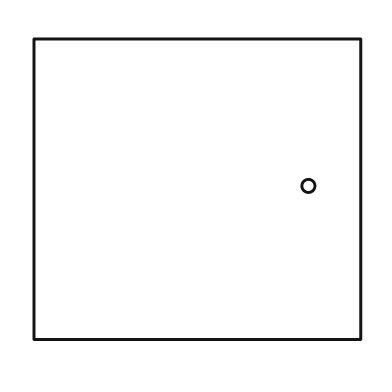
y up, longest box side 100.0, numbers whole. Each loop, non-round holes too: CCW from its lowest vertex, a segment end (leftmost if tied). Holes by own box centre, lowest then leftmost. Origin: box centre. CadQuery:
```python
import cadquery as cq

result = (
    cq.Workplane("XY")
    .moveTo(-50.0, -46.0)
    .lineTo(50.0, -46.0)
    .lineTo(50.0, 46.0)
    .lineTo(-50.0, 46.0)
    .close()
    .moveTo(34.0, 1.0)
    .circle(2.0)
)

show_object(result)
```